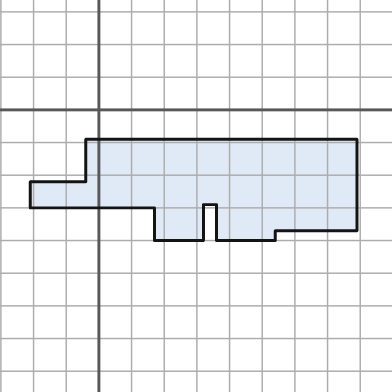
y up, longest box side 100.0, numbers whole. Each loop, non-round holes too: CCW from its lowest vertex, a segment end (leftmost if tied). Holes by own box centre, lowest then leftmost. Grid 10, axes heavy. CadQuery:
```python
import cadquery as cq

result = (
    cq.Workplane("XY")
    .moveTo(17.0, -40.0)
    .lineTo(32.0, -40.0)
    .lineTo(32.0, -29.0)
    .lineTo(36.0, -29.0)
    .lineTo(36.0, -40.0)
    .lineTo(54.0, -40.0)
    .lineTo(54.0, -37.0)
    .lineTo(79.0, -37.0)
    .lineTo(79.0, -9.0)
    .lineTo(-4.0, -9.0)
    .lineTo(-4.0, -22.0)
    .lineTo(-21.0, -22.0)
    .lineTo(-21.0, -30.0)
    .lineTo(17.0, -30.0)
    .close()
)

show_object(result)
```